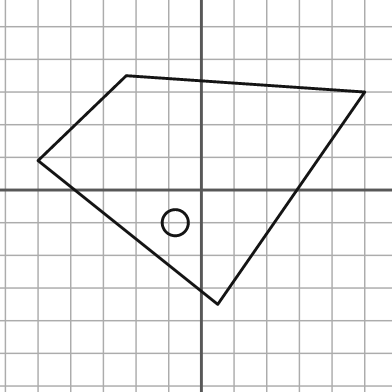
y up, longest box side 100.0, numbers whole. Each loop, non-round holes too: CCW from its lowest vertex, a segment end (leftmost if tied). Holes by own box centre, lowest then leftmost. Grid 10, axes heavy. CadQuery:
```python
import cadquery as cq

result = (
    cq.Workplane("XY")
    .moveTo(5.0, -35.0)
    .lineTo(50.0, 30.0)
    .lineTo(-23.0, 35.0)
    .lineTo(-50.0, 9.0)
    .close()
    .moveTo(-8.0, -10.0)
    .circle(4.0)
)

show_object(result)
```